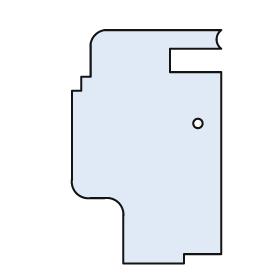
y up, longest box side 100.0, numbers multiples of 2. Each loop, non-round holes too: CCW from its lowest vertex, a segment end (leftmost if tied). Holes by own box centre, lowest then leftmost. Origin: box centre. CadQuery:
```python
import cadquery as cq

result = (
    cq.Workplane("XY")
    .moveTo(-10.0, -50.0)
    .lineTo(16.0, -50.0)
    .lineTo(16.0, -46.0)
    .lineTo(32.0, -46.0)
    .lineTo(32.0, 32.0)
    .lineTo(10.0, 32.0)
    .lineTo(10.0, 42.0)
    .lineTo(32.0, 42.0)
    .threePointArc((30.0, 46.0), (32.0, 50.0))
    .lineTo(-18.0, 50.0)
    .threePointArc((-22.0, 48.0), (-24.0, 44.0))
    .lineTo(-24.0, 30.0)
    .lineTo(-28.0, 30.0)
    .lineTo(-28.0, 24.0)
    .lineTo(-32.0, 24.0)
    .lineTo(-32.0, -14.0)
    .threePointArc((-30.0, -20.0), (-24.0, -22.0))
    .lineTo(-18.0, -22.0)
    .threePointArc((-12.0, -24.0), (-10.0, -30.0))
    .close()
    .moveTo(22.0, 10.0)
    .circle(2.0)
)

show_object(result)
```